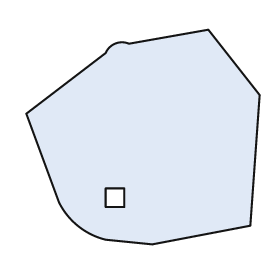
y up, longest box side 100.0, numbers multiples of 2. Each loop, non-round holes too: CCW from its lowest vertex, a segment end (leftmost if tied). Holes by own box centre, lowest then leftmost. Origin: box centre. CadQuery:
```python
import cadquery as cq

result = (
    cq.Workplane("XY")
    .moveTo(4.0, -46.0)
    .lineTo(46.0, -38.0)
    .lineTo(50.0, 18.0)
    .lineTo(28.0, 46.0)
    .lineTo(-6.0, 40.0)
    .threePointArc((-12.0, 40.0), (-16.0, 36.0))
    .lineTo(-50.0, 10.0)
    .lineTo(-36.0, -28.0)
    .threePointArc((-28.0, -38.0), (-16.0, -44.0))
    .close()
    .moveTo(-16.0, -30.0)
    .lineTo(-8.0, -30.0)
    .lineTo(-8.0, -22.0)
    .lineTo(-16.0, -22.0)
    .close()
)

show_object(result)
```